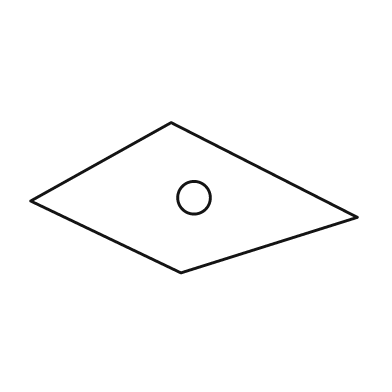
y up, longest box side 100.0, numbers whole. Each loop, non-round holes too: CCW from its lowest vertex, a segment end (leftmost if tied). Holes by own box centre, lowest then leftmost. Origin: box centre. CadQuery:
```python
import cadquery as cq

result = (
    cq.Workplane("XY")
    .moveTo(-4.0, -23.0)
    .lineTo(50.0, -6.0)
    .lineTo(-7.0, 23.0)
    .lineTo(-50.0, -1.0)
    .close()
    .moveTo(0.0, 0.0)
    .circle(5.0)
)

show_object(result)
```